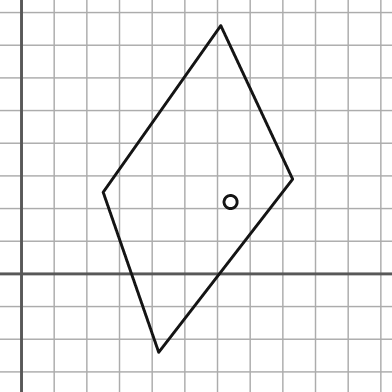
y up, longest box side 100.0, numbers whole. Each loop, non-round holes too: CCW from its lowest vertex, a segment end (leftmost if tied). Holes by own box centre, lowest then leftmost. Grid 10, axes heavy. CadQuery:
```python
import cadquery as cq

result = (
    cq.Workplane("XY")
    .moveTo(42.0, -24.0)
    .lineTo(83.0, 29.0)
    .lineTo(61.0, 76.0)
    .lineTo(25.0, 25.0)
    .close()
    .moveTo(64.0, 22.0)
    .circle(2.0)
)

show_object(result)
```